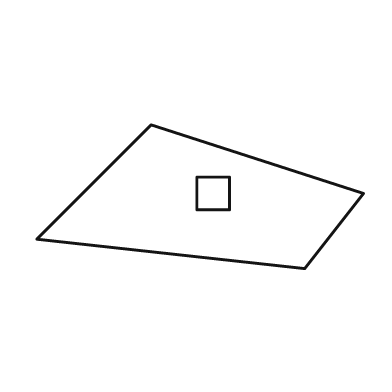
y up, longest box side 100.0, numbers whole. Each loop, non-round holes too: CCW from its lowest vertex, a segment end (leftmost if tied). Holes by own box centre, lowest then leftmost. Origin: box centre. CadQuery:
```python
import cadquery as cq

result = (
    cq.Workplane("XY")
    .moveTo(32.0, -22.0)
    .lineTo(50.0, 1.0)
    .lineTo(-15.0, 22.0)
    .lineTo(-50.0, -13.0)
    .close()
    .moveTo(-1.0, -4.0)
    .lineTo(9.0, -4.0)
    .lineTo(9.0, 6.0)
    .lineTo(-1.0, 6.0)
    .close()
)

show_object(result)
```